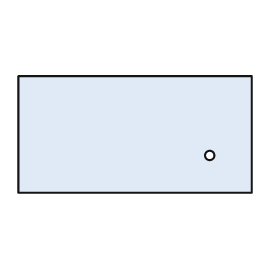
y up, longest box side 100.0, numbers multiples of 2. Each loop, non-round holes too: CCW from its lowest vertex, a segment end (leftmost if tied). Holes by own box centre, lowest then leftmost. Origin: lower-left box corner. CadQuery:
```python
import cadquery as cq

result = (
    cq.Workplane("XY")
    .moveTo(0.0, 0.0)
    .lineTo(100.0, 0.0)
    .lineTo(100.0, 50.0)
    .lineTo(0.0, 50.0)
    .close()
    .moveTo(82.0, 16.0)
    .circle(2.0)
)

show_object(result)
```